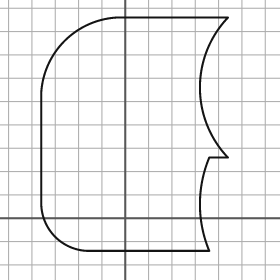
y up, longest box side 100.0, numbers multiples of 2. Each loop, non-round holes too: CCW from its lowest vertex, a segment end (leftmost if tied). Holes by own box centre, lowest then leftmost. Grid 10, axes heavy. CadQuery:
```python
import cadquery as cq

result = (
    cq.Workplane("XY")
    .moveTo(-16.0, -14.0)
    .lineTo(36.0, -14.0)
    .threePointArc((32.0, 6.0), (36.0, 26.0))
    .lineTo(44.0, 26.0)
    .threePointArc((32.0, 56.0), (44.0, 86.0))
    .lineTo(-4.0, 86.0)
    .threePointArc((-26.0, 76.0), (-36.0, 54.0))
    .lineTo(-36.0, 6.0)
    .threePointArc((-30.0, -8.0), (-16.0, -14.0))
    .close()
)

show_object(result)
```